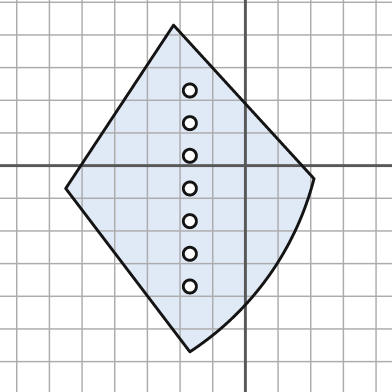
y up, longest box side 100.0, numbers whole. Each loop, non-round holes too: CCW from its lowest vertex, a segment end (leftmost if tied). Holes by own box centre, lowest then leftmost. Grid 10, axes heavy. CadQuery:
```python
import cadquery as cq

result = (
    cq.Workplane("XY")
    .moveTo(-17.0, -57.0)
    .threePointArc((7.0, -34.0), (21.0, -4.0))
    .lineTo(-22.0, 43.0)
    .lineTo(-55.0, -7.0)
    .close()
    .moveTo(-17.0, -37.0)
    .circle(2.0)
    .moveTo(-17.0, -27.0)
    .circle(2.0)
    .moveTo(-17.0, -17.0)
    .circle(2.0)
    .moveTo(-17.0, -7.0)
    .circle(2.0)
    .moveTo(-17.0, 3.0)
    .circle(2.0)
    .moveTo(-17.0, 13.0)
    .circle(2.0)
    .moveTo(-17.0, 23.0)
    .circle(2.0)
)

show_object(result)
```